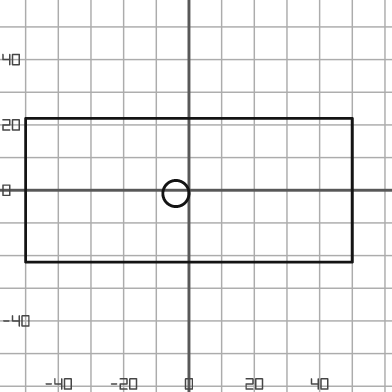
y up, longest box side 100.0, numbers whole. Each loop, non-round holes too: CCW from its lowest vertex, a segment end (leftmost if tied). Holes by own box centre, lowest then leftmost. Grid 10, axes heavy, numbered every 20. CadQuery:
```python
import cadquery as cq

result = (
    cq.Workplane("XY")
    .moveTo(-50.0, -22.0)
    .lineTo(50.0, -22.0)
    .lineTo(50.0, 22.0)
    .lineTo(-50.0, 22.0)
    .close()
    .moveTo(-4.0, -1.0)
    .circle(4.0)
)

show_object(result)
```